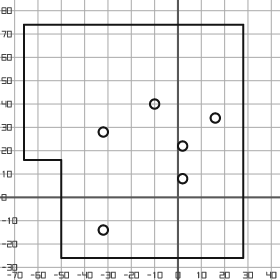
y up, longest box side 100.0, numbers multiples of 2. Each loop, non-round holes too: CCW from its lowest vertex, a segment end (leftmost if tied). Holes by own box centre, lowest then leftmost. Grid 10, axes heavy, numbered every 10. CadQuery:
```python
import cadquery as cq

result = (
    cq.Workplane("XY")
    .moveTo(-50.0, -26.0)
    .lineTo(28.0, -26.0)
    .lineTo(28.0, 74.0)
    .lineTo(-66.0, 74.0)
    .lineTo(-66.0, 16.0)
    .lineTo(-50.0, 16.0)
    .close()
    .moveTo(-32.0, -14.0)
    .circle(2.0)
    .moveTo(2.0, 8.0)
    .circle(2.0)
    .moveTo(2.0, 22.0)
    .circle(2.0)
    .moveTo(-32.0, 28.0)
    .circle(2.0)
    .moveTo(16.0, 34.0)
    .circle(2.0)
    .moveTo(-10.0, 40.0)
    .circle(2.0)
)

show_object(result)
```